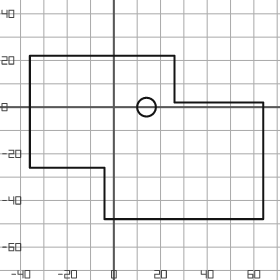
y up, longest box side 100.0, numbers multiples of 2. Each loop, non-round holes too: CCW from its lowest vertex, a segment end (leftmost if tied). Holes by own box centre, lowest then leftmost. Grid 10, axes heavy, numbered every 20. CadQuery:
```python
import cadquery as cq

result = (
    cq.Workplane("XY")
    .moveTo(-4.0, -48.0)
    .lineTo(64.0, -48.0)
    .lineTo(64.0, 2.0)
    .lineTo(26.0, 2.0)
    .lineTo(26.0, 22.0)
    .lineTo(-36.0, 22.0)
    .lineTo(-36.0, -26.0)
    .lineTo(-4.0, -26.0)
    .close()
    .moveTo(14.0, 0.0)
    .circle(4.0)
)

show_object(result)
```